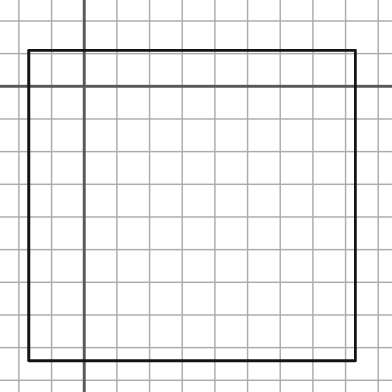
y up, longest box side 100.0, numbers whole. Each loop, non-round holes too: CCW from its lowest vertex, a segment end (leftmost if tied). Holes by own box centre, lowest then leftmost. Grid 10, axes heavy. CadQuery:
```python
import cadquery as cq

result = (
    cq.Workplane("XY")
    .moveTo(-17.0, -84.0)
    .lineTo(83.0, -84.0)
    .lineTo(83.0, 11.0)
    .lineTo(-17.0, 11.0)
    .close()
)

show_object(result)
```